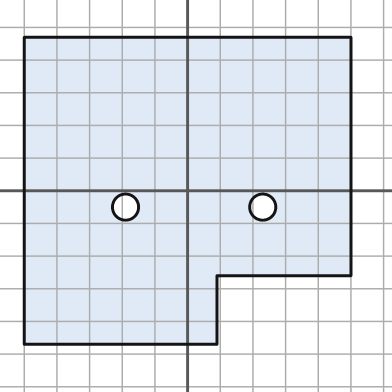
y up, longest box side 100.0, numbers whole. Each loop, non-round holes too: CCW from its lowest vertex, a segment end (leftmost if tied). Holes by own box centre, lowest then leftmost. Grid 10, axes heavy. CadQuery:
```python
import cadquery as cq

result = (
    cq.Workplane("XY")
    .moveTo(-50.0, -47.0)
    .lineTo(9.0, -47.0)
    .lineTo(9.0, -26.0)
    .lineTo(50.0, -26.0)
    .lineTo(50.0, 47.0)
    .lineTo(-50.0, 47.0)
    .close()
    .moveTo(-19.0, -5.0)
    .circle(4.0)
    .moveTo(23.0, -5.0)
    .circle(4.0)
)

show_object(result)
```